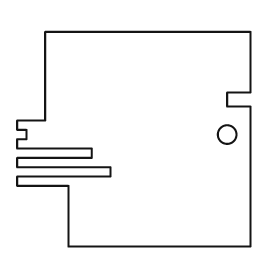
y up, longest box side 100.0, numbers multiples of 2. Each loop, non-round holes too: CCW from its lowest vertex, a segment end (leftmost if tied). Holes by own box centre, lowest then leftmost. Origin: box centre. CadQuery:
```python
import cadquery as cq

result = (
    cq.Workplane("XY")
    .moveTo(-28.0, -46.0)
    .lineTo(50.0, -46.0)
    .lineTo(50.0, 14.0)
    .lineTo(40.0, 14.0)
    .lineTo(40.0, 20.0)
    .lineTo(50.0, 20.0)
    .lineTo(50.0, 46.0)
    .lineTo(-38.0, 46.0)
    .lineTo(-38.0, 8.0)
    .lineTo(-50.0, 8.0)
    .lineTo(-50.0, 4.0)
    .lineTo(-46.0, 4.0)
    .lineTo(-46.0, 0.0)
    .lineTo(-50.0, 0.0)
    .lineTo(-50.0, -4.0)
    .lineTo(-18.0, -4.0)
    .lineTo(-18.0, -8.0)
    .lineTo(-50.0, -8.0)
    .lineTo(-50.0, -12.0)
    .lineTo(-10.0, -12.0)
    .lineTo(-10.0, -16.0)
    .lineTo(-50.0, -16.0)
    .lineTo(-50.0, -20.0)
    .lineTo(-28.0, -20.0)
    .close()
    .moveTo(40.0, 2.0)
    .circle(4.0)
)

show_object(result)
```